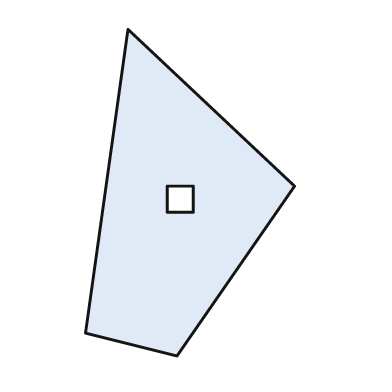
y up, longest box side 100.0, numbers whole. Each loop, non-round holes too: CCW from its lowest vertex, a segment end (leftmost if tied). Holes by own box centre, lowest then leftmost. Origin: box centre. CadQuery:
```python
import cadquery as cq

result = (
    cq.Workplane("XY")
    .moveTo(-4.0, -50.0)
    .lineTo(32.0, 2.0)
    .lineTo(-19.0, 50.0)
    .lineTo(-32.0, -43.0)
    .close()
    .moveTo(-7.0, -6.0)
    .lineTo(1.0, -6.0)
    .lineTo(1.0, 2.0)
    .lineTo(-7.0, 2.0)
    .close()
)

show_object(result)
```